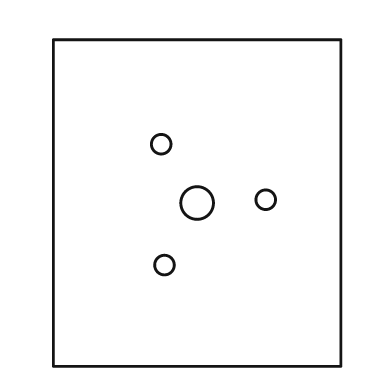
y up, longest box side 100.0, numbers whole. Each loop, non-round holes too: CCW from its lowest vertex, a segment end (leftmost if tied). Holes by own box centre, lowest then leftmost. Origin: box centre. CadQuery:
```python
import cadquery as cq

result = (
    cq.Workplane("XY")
    .moveTo(-44.0, -50.0)
    .lineTo(44.0, -50.0)
    .lineTo(44.0, 50.0)
    .lineTo(-44.0, 50.0)
    .close()
    .moveTo(-10.0, -19.0)
    .circle(3.0)
    .moveTo(0.0, 0.0)
    .circle(5.0)
    .moveTo(21.0, 1.0)
    .circle(3.0)
    .moveTo(-11.0, 18.0)
    .circle(3.0)
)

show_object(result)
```